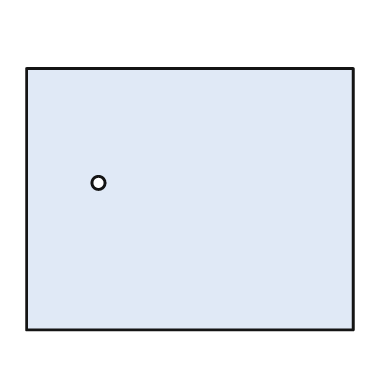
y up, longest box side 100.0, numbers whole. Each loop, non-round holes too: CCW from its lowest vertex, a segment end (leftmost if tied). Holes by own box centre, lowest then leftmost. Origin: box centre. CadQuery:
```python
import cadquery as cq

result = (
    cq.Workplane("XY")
    .moveTo(-50.0, -40.0)
    .lineTo(50.0, -40.0)
    .lineTo(50.0, 40.0)
    .lineTo(-50.0, 40.0)
    .close()
    .moveTo(-28.0, 5.0)
    .circle(2.0)
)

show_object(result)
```